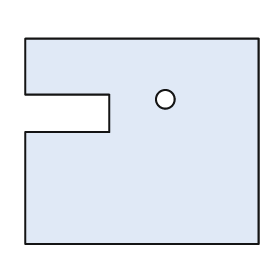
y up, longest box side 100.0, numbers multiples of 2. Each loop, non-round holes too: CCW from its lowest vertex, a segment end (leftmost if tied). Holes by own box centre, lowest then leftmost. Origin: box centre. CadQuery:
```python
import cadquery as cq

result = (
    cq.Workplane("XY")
    .moveTo(-50.0, -44.0)
    .lineTo(50.0, -44.0)
    .lineTo(50.0, 44.0)
    .lineTo(-50.0, 44.0)
    .lineTo(-50.0, 20.0)
    .lineTo(-14.0, 20.0)
    .lineTo(-14.0, 4.0)
    .lineTo(-50.0, 4.0)
    .close()
    .moveTo(10.0, 18.0)
    .circle(4.0)
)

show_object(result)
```